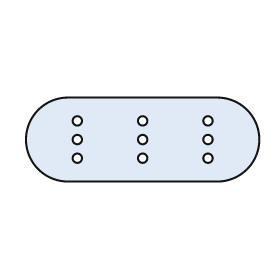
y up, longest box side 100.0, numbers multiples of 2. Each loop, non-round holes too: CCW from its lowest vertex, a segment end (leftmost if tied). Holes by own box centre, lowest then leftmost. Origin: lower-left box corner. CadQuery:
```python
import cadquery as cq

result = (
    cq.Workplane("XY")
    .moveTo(18.0, 0.0)
    .lineTo(82.0, 0.0)
    .threePointArc((100.0, 18.0), (82.0, 36.0))
    .lineTo(18.0, 36.0)
    .threePointArc((0.0, 18.0), (18.0, 0.0))
    .close()
    .moveTo(22.0, 10.0)
    .circle(2.0)
    .moveTo(50.0, 10.0)
    .circle(2.0)
    .moveTo(78.0, 10.0)
    .circle(2.0)
    .moveTo(22.0, 18.0)
    .circle(2.0)
    .moveTo(50.0, 18.0)
    .circle(2.0)
    .moveTo(78.0, 18.0)
    .circle(2.0)
    .moveTo(22.0, 26.0)
    .circle(2.0)
    .moveTo(50.0, 26.0)
    .circle(2.0)
    .moveTo(78.0, 26.0)
    .circle(2.0)
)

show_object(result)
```